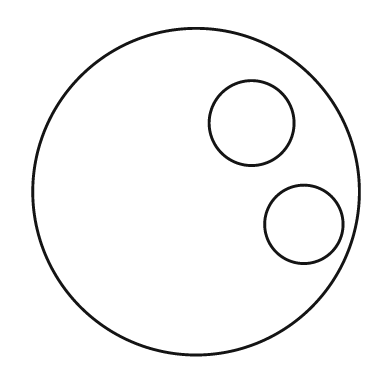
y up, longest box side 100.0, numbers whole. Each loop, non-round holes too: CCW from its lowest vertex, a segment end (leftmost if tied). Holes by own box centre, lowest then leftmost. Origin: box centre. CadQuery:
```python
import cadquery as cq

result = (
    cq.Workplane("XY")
    .moveTo(0.0, 0.0)
    .circle(50.0)
    .moveTo(33.0, -10.0)
    .circle(12.0)
    .moveTo(17.0, 21.0)
    .circle(13.0)
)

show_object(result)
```